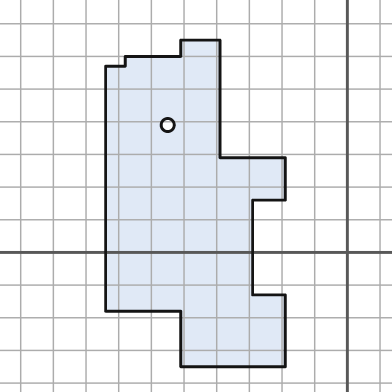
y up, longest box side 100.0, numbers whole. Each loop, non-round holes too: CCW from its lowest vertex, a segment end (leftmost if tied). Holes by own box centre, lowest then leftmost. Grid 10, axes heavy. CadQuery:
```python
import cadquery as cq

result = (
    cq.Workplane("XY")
    .moveTo(-51.0, -35.0)
    .lineTo(-19.0, -35.0)
    .lineTo(-19.0, -13.0)
    .lineTo(-29.0, -13.0)
    .lineTo(-29.0, 16.0)
    .lineTo(-19.0, 16.0)
    .lineTo(-19.0, 29.0)
    .lineTo(-39.0, 29.0)
    .lineTo(-39.0, 65.0)
    .lineTo(-51.0, 65.0)
    .lineTo(-51.0, 60.0)
    .lineTo(-68.0, 60.0)
    .lineTo(-68.0, 57.0)
    .lineTo(-74.0, 57.0)
    .lineTo(-74.0, -18.0)
    .lineTo(-51.0, -18.0)
    .close()
    .moveTo(-55.0, 39.0)
    .circle(2.0)
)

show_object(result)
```